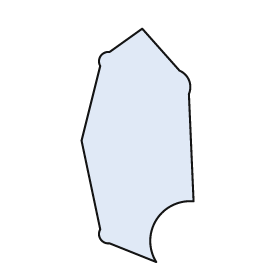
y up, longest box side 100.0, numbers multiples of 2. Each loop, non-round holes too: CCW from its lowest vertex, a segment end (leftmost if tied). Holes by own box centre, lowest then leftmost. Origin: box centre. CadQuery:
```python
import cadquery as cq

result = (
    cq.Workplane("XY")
    .moveTo(8.0, -50.0)
    .threePointArc((8.0, -32.0), (24.0, -24.0))
    .lineTo(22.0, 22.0)
    .threePointArc((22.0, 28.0), (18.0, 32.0))
    .lineTo(2.0, 50.0)
    .lineTo(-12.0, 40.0)
    .threePointArc((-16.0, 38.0), (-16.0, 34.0))
    .lineTo(-24.0, 2.0)
    .lineTo(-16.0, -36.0)
    .threePointArc((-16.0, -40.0), (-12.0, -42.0))
    .close()
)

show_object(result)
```